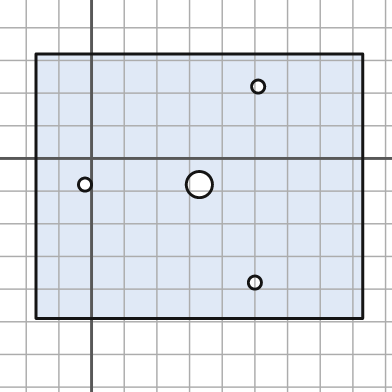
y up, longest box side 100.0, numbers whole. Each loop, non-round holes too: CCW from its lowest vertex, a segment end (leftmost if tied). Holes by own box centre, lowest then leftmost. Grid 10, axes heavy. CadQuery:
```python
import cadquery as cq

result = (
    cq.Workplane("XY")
    .moveTo(-17.0, -49.0)
    .lineTo(83.0, -49.0)
    .lineTo(83.0, 32.0)
    .lineTo(-17.0, 32.0)
    .close()
    .moveTo(50.0, -38.0)
    .circle(2.0)
    .moveTo(-2.0, -8.0)
    .circle(2.0)
    .moveTo(33.0, -8.0)
    .circle(4.0)
    .moveTo(51.0, 22.0)
    .circle(2.0)
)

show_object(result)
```